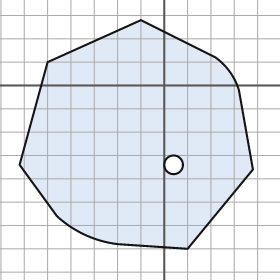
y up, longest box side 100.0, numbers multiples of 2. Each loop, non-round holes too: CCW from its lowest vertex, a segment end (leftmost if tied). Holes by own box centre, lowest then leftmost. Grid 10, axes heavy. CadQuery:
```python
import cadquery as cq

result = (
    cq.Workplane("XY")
    .moveTo(10.0, -70.0)
    .lineTo(38.0, -36.0)
    .lineTo(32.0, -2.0)
    .threePointArc((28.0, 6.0), (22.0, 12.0))
    .lineTo(-10.0, 28.0)
    .lineTo(-50.0, 10.0)
    .lineTo(-62.0, -34.0)
    .lineTo(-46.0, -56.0)
    .threePointArc((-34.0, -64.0), (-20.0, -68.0))
    .close()
    .moveTo(4.0, -34.0)
    .circle(4.0)
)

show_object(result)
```